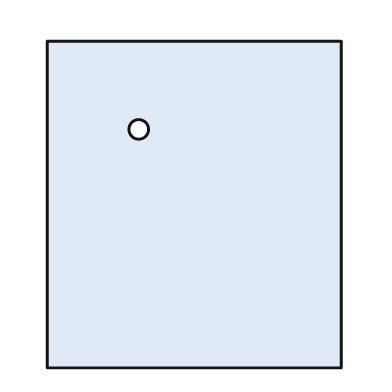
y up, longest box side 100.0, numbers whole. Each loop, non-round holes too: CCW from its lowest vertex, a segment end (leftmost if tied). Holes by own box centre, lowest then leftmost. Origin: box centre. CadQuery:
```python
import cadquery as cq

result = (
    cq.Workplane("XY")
    .moveTo(-45.0, -50.0)
    .lineTo(45.0, -50.0)
    .lineTo(45.0, 50.0)
    .lineTo(-45.0, 50.0)
    .close()
    .moveTo(-17.0, 23.0)
    .circle(3.0)
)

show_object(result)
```